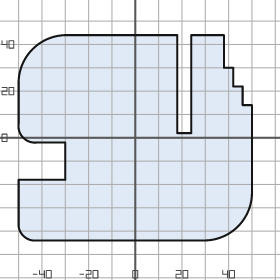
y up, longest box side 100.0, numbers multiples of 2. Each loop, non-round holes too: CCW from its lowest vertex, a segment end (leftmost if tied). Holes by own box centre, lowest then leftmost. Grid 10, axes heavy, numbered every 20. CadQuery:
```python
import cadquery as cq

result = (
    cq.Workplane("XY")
    .moveTo(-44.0, -44.0)
    .lineTo(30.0, -44.0)
    .threePointArc((44.0, -38.0), (50.0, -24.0))
    .lineTo(50.0, 14.0)
    .lineTo(46.0, 14.0)
    .lineTo(46.0, 22.0)
    .lineTo(42.0, 22.0)
    .lineTo(42.0, 30.0)
    .lineTo(38.0, 30.0)
    .lineTo(38.0, 44.0)
    .lineTo(24.0, 44.0)
    .lineTo(24.0, 2.0)
    .lineTo(18.0, 2.0)
    .lineTo(18.0, 44.0)
    .lineTo(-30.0, 44.0)
    .threePointArc((-44.0, 38.0), (-50.0, 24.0))
    .lineTo(-50.0, 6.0)
    .threePointArc((-48.0, 0.0), (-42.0, -2.0))
    .lineTo(-30.0, -2.0)
    .lineTo(-30.0, -18.0)
    .lineTo(-50.0, -18.0)
    .lineTo(-50.0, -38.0)
    .threePointArc((-48.0, -42.0), (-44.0, -44.0))
    .close()
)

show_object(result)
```